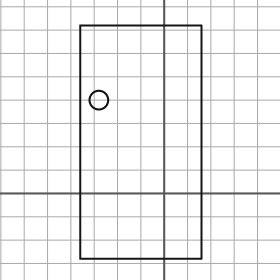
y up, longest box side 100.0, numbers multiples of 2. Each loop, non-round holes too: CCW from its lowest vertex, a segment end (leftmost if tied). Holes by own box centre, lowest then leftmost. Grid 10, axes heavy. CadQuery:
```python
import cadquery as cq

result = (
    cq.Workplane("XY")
    .moveTo(-36.0, -28.0)
    .lineTo(16.0, -28.0)
    .lineTo(16.0, 72.0)
    .lineTo(-36.0, 72.0)
    .close()
    .moveTo(-28.0, 40.0)
    .circle(4.0)
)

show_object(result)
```